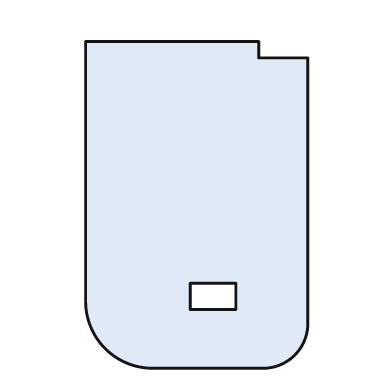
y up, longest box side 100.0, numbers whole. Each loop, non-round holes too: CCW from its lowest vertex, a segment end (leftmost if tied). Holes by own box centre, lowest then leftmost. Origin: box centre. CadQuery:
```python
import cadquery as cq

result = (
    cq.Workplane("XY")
    .moveTo(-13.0, -50.0)
    .lineTo(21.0, -50.0)
    .threePointArc((30.0, -46.0), (34.0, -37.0))
    .lineTo(34.0, 45.0)
    .lineTo(19.0, 45.0)
    .lineTo(19.0, 50.0)
    .lineTo(-34.0, 50.0)
    .lineTo(-34.0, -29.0)
    .threePointArc((-28.0, -44.0), (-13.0, -50.0))
    .close()
    .moveTo(-2.0, -32.0)
    .lineTo(12.0, -32.0)
    .lineTo(12.0, -24.0)
    .lineTo(-2.0, -24.0)
    .close()
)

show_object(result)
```